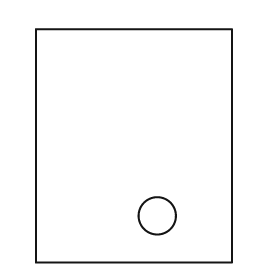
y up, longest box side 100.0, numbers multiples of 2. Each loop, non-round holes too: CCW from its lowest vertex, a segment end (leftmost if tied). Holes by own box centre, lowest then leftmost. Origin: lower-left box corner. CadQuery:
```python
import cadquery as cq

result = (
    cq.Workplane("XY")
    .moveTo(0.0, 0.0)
    .lineTo(84.0, 0.0)
    .lineTo(84.0, 100.0)
    .lineTo(0.0, 100.0)
    .close()
    .moveTo(52.0, 20.0)
    .circle(8.0)
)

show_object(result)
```